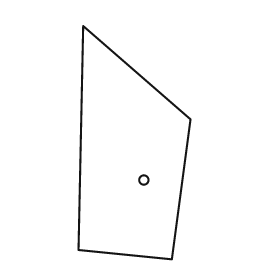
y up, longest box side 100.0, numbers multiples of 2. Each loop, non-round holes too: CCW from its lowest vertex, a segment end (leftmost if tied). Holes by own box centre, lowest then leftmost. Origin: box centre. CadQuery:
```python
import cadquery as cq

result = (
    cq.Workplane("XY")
    .moveTo(16.0, -50.0)
    .lineTo(24.0, 10.0)
    .lineTo(-22.0, 50.0)
    .lineTo(-24.0, -46.0)
    .close()
    .moveTo(4.0, -16.0)
    .circle(2.0)
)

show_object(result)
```